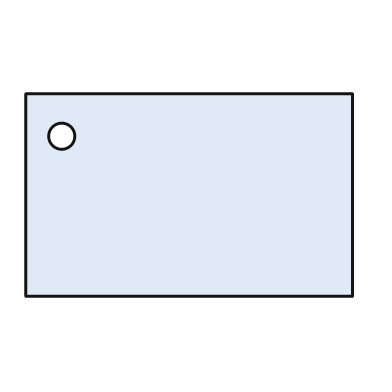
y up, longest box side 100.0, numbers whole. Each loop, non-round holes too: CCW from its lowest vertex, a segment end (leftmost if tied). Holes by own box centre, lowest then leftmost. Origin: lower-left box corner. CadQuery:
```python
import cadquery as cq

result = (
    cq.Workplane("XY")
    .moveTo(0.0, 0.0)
    .lineTo(100.0, 0.0)
    .lineTo(100.0, 62.0)
    .lineTo(0.0, 62.0)
    .close()
    .moveTo(11.0, 49.0)
    .circle(4.0)
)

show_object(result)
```